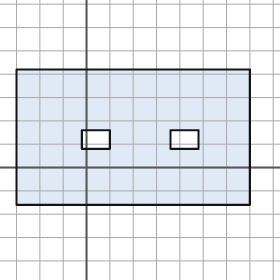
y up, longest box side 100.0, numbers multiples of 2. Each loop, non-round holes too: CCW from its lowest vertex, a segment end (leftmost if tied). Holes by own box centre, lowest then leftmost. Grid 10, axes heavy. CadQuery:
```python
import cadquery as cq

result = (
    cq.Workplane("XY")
    .moveTo(-30.0, -16.0)
    .lineTo(70.0, -16.0)
    .lineTo(70.0, 42.0)
    .lineTo(-30.0, 42.0)
    .close()
    .moveTo(-2.0, 8.0)
    .lineTo(10.0, 8.0)
    .lineTo(10.0, 16.0)
    .lineTo(-2.0, 16.0)
    .close()
    .moveTo(36.0, 8.0)
    .lineTo(48.0, 8.0)
    .lineTo(48.0, 16.0)
    .lineTo(36.0, 16.0)
    .close()
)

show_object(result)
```